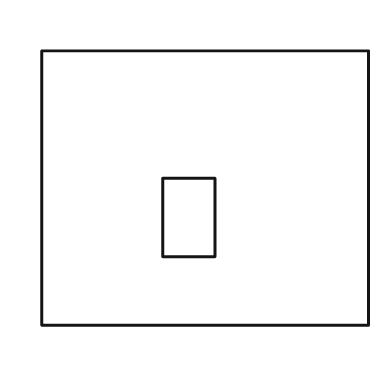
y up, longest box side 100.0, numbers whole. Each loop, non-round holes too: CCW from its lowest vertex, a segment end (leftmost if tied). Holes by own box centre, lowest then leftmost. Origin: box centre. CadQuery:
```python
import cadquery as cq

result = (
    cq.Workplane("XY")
    .moveTo(-50.0, -42.0)
    .lineTo(50.0, -42.0)
    .lineTo(50.0, 42.0)
    .lineTo(-50.0, 42.0)
    .close()
    .moveTo(-13.0, -21.0)
    .lineTo(3.0, -21.0)
    .lineTo(3.0, 3.0)
    .lineTo(-13.0, 3.0)
    .close()
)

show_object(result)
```